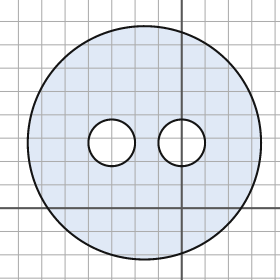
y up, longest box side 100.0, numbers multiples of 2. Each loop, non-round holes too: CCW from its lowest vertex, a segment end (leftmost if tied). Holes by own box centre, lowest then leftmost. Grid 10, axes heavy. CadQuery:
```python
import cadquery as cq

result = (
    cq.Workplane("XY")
    .moveTo(-16.0, 28.0)
    .circle(50.0)
    .moveTo(-30.0, 28.0)
    .circle(10.0)
    .moveTo(0.0, 28.0)
    .circle(10.0)
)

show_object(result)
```